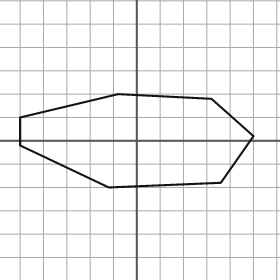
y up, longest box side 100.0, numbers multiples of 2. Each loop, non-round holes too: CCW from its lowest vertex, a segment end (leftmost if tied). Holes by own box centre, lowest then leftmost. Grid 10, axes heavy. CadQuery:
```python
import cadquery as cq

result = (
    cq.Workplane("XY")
    .moveTo(-12.0, -20.0)
    .lineTo(36.0, -18.0)
    .lineTo(50.0, 2.0)
    .lineTo(32.0, 18.0)
    .lineTo(-8.0, 20.0)
    .lineTo(-50.0, 10.0)
    .lineTo(-50.0, -2.0)
    .close()
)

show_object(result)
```